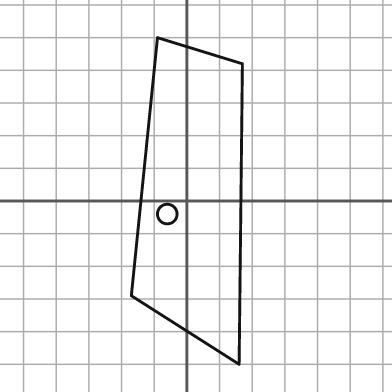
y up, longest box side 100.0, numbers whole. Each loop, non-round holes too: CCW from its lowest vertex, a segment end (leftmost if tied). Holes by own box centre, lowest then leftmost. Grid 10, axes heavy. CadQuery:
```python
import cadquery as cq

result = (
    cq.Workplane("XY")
    .moveTo(16.0, -50.0)
    .lineTo(17.0, 42.0)
    .lineTo(-9.0, 50.0)
    .lineTo(-17.0, -29.0)
    .close()
    .moveTo(-6.0, -4.0)
    .circle(3.0)
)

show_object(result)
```